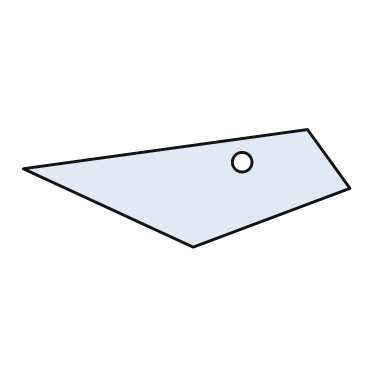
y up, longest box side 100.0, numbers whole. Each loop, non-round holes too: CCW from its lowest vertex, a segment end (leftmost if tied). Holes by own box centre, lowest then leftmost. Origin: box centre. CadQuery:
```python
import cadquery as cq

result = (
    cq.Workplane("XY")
    .moveTo(2.0, -18.0)
    .lineTo(50.0, 0.0)
    .lineTo(37.0, 18.0)
    .lineTo(-50.0, 6.0)
    .close()
    .moveTo(17.0, 8.0)
    .circle(3.0)
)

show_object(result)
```